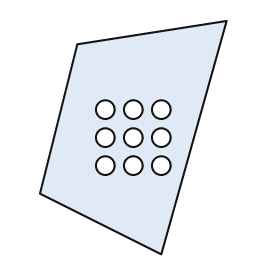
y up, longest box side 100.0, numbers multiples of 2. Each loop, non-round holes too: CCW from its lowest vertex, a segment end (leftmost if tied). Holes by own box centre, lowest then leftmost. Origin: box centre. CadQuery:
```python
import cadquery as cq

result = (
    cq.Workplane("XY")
    .moveTo(12.0, -50.0)
    .lineTo(40.0, 50.0)
    .lineTo(-24.0, 40.0)
    .lineTo(-40.0, -24.0)
    .close()
    .moveTo(-12.0, -12.0)
    .circle(4.0)
    .moveTo(0.0, -12.0)
    .circle(4.0)
    .moveTo(12.0, -12.0)
    .circle(4.0)
    .moveTo(-12.0, 0.0)
    .circle(4.0)
    .moveTo(0.0, 0.0)
    .circle(4.0)
    .moveTo(12.0, 0.0)
    .circle(4.0)
    .moveTo(-12.0, 12.0)
    .circle(4.0)
    .moveTo(0.0, 12.0)
    .circle(4.0)
    .moveTo(12.0, 12.0)
    .circle(4.0)
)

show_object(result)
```